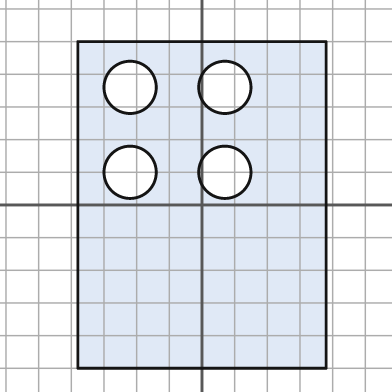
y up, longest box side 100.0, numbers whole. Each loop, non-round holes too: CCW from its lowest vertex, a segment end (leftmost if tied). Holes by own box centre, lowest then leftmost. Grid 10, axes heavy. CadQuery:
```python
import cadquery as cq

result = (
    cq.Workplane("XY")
    .moveTo(-38.0, -50.0)
    .lineTo(38.0, -50.0)
    .lineTo(38.0, 50.0)
    .lineTo(-38.0, 50.0)
    .close()
    .moveTo(-22.0, 10.0)
    .circle(8.0)
    .moveTo(7.0, 10.0)
    .circle(8.0)
    .moveTo(-22.0, 36.0)
    .circle(8.0)
    .moveTo(7.0, 36.0)
    .circle(8.0)
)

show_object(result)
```